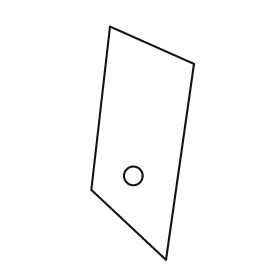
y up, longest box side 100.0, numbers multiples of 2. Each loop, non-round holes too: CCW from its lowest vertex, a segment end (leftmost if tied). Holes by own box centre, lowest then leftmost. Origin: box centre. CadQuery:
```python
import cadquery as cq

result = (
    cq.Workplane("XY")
    .moveTo(10.0, -50.0)
    .lineTo(22.0, 34.0)
    .lineTo(-14.0, 50.0)
    .lineTo(-22.0, -20.0)
    .close()
    .moveTo(-4.0, -14.0)
    .circle(4.0)
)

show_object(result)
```